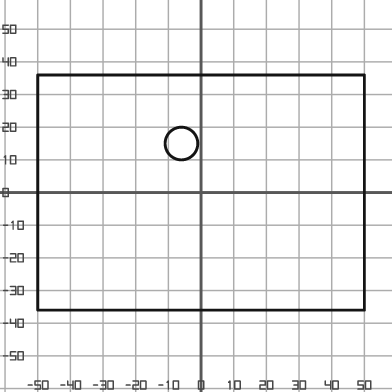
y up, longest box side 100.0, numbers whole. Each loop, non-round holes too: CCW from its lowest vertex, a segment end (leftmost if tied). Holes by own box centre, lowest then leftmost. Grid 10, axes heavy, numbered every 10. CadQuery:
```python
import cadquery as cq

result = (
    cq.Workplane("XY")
    .moveTo(-50.0, -36.0)
    .lineTo(50.0, -36.0)
    .lineTo(50.0, 36.0)
    .lineTo(-50.0, 36.0)
    .close()
    .moveTo(-6.0, 15.0)
    .circle(5.0)
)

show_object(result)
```